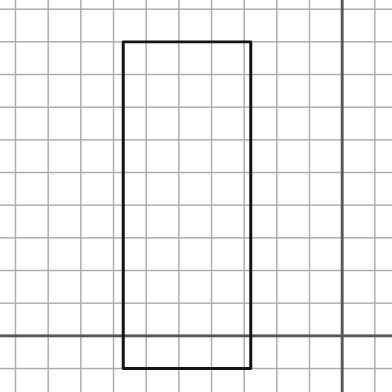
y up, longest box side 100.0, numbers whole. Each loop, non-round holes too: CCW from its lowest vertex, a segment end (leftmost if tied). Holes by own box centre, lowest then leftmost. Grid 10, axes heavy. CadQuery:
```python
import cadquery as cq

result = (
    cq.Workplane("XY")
    .moveTo(-67.0, -10.0)
    .lineTo(-28.0, -10.0)
    .lineTo(-28.0, 90.0)
    .lineTo(-67.0, 90.0)
    .close()
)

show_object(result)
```